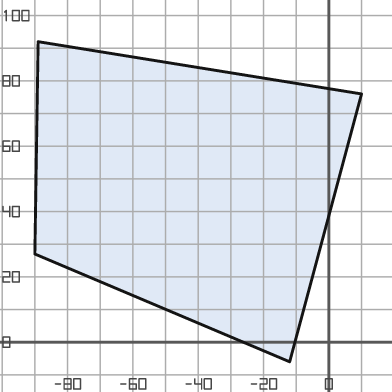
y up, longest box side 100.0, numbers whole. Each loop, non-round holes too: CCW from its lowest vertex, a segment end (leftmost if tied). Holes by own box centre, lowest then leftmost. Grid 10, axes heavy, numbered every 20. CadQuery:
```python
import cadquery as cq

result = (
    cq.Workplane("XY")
    .moveTo(-12.0, -6.0)
    .lineTo(10.0, 76.0)
    .lineTo(-89.0, 92.0)
    .lineTo(-90.0, 27.0)
    .close()
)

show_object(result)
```